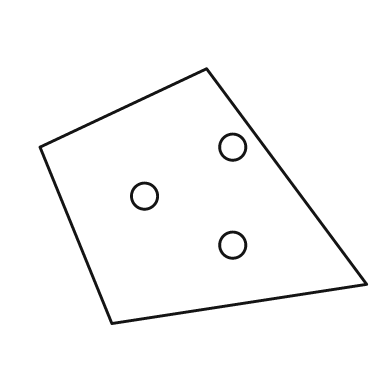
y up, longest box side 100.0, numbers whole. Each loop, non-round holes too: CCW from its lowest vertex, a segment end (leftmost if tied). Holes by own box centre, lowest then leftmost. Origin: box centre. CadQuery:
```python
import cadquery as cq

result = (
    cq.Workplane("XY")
    .moveTo(-28.0, -39.0)
    .lineTo(50.0, -27.0)
    .lineTo(1.0, 39.0)
    .lineTo(-50.0, 15.0)
    .close()
    .moveTo(9.0, -15.0)
    .circle(4.0)
    .moveTo(-18.0, 0.0)
    .circle(4.0)
    .moveTo(9.0, 15.0)
    .circle(4.0)
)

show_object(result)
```